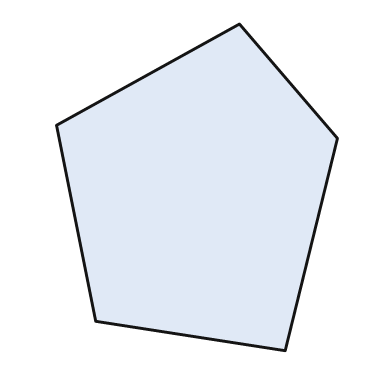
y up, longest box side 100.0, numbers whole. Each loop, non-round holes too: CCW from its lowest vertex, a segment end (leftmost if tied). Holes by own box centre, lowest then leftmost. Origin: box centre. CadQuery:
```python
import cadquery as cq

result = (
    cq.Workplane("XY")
    .moveTo(27.0, -50.0)
    .lineTo(43.0, 15.0)
    .lineTo(13.0, 50.0)
    .lineTo(-43.0, 19.0)
    .lineTo(-31.0, -41.0)
    .close()
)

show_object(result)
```